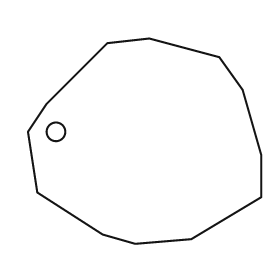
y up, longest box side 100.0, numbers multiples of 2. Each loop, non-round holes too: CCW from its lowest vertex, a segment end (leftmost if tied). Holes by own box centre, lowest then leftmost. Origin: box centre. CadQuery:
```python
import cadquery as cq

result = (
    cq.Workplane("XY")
    .moveTo(-4.0, -44.0)
    .lineTo(20.0, -42.0)
    .lineTo(50.0, -24.0)
    .lineTo(50.0, -6.0)
    .lineTo(42.0, 22.0)
    .lineTo(32.0, 36.0)
    .lineTo(2.0, 44.0)
    .lineTo(-16.0, 42.0)
    .lineTo(-42.0, 16.0)
    .lineTo(-50.0, 4.0)
    .lineTo(-46.0, -22.0)
    .lineTo(-18.0, -40.0)
    .close()
    .moveTo(-38.0, 4.0)
    .circle(4.0)
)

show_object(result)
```